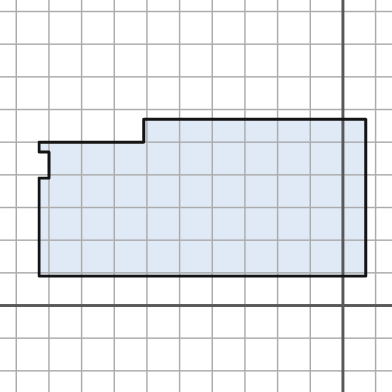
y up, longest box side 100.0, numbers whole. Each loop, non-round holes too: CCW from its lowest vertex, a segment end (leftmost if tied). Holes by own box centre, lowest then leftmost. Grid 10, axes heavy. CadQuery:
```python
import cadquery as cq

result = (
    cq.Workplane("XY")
    .moveTo(-93.0, 9.0)
    .lineTo(7.0, 9.0)
    .lineTo(7.0, 57.0)
    .lineTo(-61.0, 57.0)
    .lineTo(-61.0, 50.0)
    .lineTo(-93.0, 50.0)
    .lineTo(-93.0, 47.0)
    .lineTo(-90.0, 47.0)
    .lineTo(-90.0, 39.0)
    .lineTo(-93.0, 39.0)
    .close()
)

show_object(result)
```